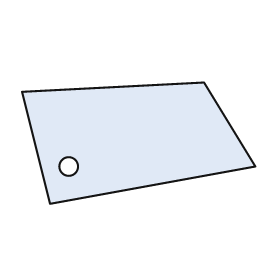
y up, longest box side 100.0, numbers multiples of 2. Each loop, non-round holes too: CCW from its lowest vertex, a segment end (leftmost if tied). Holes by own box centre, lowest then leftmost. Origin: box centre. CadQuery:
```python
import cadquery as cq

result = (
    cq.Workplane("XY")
    .moveTo(-38.0, -26.0)
    .lineTo(50.0, -10.0)
    .lineTo(28.0, 26.0)
    .lineTo(-50.0, 22.0)
    .close()
    .moveTo(-30.0, -10.0)
    .circle(4.0)
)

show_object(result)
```